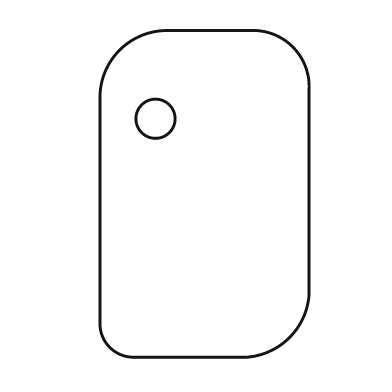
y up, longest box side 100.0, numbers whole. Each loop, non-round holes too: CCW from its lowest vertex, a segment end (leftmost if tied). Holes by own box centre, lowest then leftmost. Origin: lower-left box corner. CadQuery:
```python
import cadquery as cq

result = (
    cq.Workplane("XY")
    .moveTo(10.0, 0.0)
    .lineTo(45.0, 0.0)
    .threePointArc((58.0, 6.0), (64.0, 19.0))
    .lineTo(64.0, 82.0)
    .threePointArc((59.0, 95.0), (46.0, 100.0))
    .lineTo(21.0, 100.0)
    .threePointArc((6.0, 94.0), (0.0, 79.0))
    .lineTo(0.0, 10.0)
    .threePointArc((3.0, 3.0), (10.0, 0.0))
    .close()
    .moveTo(17.0, 73.0)
    .circle(6.0)
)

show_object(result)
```